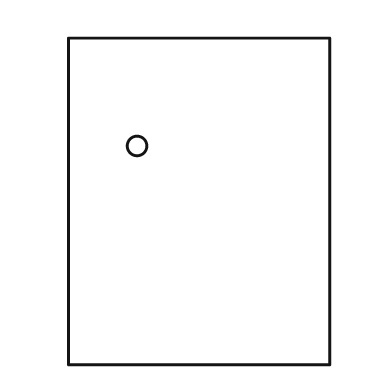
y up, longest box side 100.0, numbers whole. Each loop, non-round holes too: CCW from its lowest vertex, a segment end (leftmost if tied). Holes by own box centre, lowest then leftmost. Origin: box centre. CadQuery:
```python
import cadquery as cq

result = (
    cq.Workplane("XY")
    .moveTo(-40.0, -50.0)
    .lineTo(40.0, -50.0)
    .lineTo(40.0, 50.0)
    .lineTo(-40.0, 50.0)
    .close()
    .moveTo(-19.0, 17.0)
    .circle(3.0)
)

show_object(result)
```